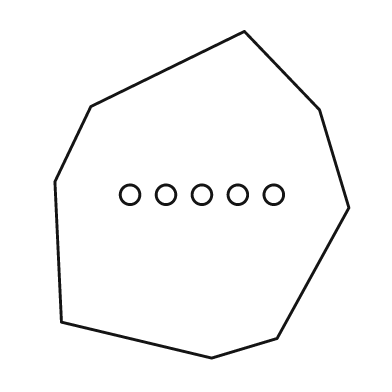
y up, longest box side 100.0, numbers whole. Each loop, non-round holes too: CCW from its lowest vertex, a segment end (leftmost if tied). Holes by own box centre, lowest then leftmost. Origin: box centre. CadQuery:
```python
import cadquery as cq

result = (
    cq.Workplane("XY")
    .moveTo(3.0, -50.0)
    .lineTo(23.0, -44.0)
    .lineTo(45.0, -4.0)
    .lineTo(36.0, 26.0)
    .lineTo(13.0, 50.0)
    .lineTo(-34.0, 27.0)
    .lineTo(-45.0, 4.0)
    .lineTo(-43.0, -39.0)
    .close()
    .moveTo(-22.0, 0.0)
    .circle(3.0)
    .moveTo(-11.0, 0.0)
    .circle(3.0)
    .moveTo(0.0, 0.0)
    .circle(3.0)
    .moveTo(11.0, 0.0)
    .circle(3.0)
    .moveTo(22.0, 0.0)
    .circle(3.0)
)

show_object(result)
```